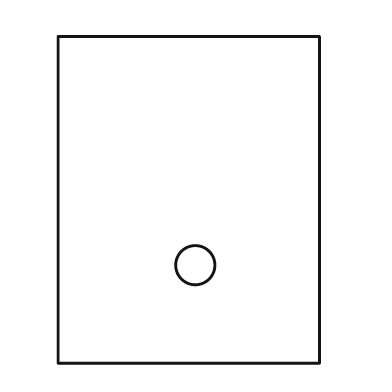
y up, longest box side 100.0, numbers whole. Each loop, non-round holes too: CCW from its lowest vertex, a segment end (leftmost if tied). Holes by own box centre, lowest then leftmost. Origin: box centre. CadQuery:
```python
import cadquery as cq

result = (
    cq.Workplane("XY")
    .moveTo(-40.0, -50.0)
    .lineTo(40.0, -50.0)
    .lineTo(40.0, 50.0)
    .lineTo(-40.0, 50.0)
    .close()
    .moveTo(2.0, -20.0)
    .circle(6.0)
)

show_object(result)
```